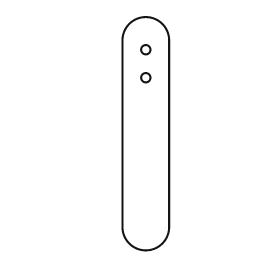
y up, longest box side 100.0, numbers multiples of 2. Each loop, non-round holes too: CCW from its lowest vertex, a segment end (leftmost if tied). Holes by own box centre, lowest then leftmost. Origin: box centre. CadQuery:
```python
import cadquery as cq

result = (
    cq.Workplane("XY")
    .moveTo(-10.0, -40.0)
    .threePointArc((0.0, -50.0), (10.0, -40.0))
    .lineTo(10.0, 40.0)
    .threePointArc((0.0, 50.0), (-10.0, 40.0))
    .close()
    .moveTo(0.0, 24.0)
    .circle(2.0)
    .moveTo(0.0, 36.0)
    .circle(2.0)
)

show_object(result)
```